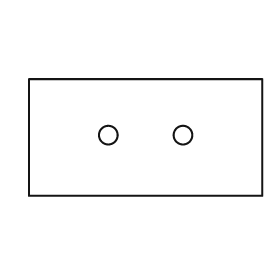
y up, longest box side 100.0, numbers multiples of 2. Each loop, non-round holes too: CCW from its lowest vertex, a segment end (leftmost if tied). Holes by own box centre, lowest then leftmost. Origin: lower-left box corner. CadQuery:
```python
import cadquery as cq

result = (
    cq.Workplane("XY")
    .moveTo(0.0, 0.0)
    .lineTo(100.0, 0.0)
    .lineTo(100.0, 50.0)
    .lineTo(0.0, 50.0)
    .close()
    .moveTo(34.0, 26.0)
    .circle(4.0)
    .moveTo(66.0, 26.0)
    .circle(4.0)
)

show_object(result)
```